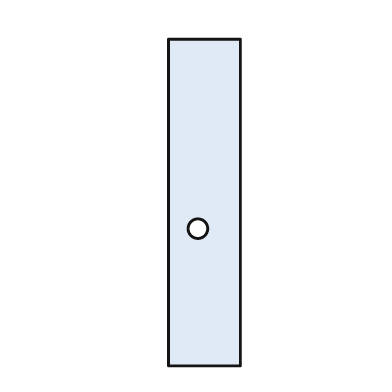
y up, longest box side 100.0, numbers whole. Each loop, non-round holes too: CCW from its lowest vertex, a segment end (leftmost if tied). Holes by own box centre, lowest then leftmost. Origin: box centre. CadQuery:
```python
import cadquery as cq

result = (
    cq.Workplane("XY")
    .moveTo(-11.0, -50.0)
    .lineTo(11.0, -50.0)
    .lineTo(11.0, 50.0)
    .lineTo(-11.0, 50.0)
    .close()
    .moveTo(-2.0, -8.0)
    .circle(3.0)
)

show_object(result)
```